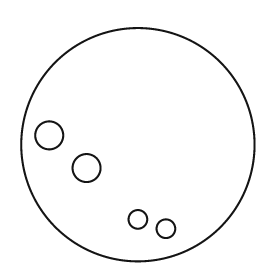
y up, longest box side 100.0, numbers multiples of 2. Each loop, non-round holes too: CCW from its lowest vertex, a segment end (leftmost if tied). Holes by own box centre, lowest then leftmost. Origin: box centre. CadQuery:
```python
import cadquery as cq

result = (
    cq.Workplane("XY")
    .moveTo(0.0, 0.0)
    .circle(50.0)
    .moveTo(12.0, -36.0)
    .circle(4.0)
    .moveTo(0.0, -32.0)
    .circle(4.0)
    .moveTo(-22.0, -10.0)
    .circle(6.0)
    .moveTo(-38.0, 4.0)
    .circle(6.0)
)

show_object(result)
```